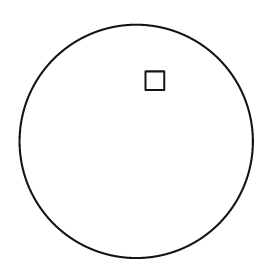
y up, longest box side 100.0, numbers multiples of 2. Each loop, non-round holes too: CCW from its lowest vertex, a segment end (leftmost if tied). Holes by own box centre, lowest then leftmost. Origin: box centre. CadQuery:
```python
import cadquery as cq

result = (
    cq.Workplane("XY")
    .moveTo(0.0, 0.0)
    .circle(50.0)
    .moveTo(4.0, 22.0)
    .lineTo(12.0, 22.0)
    .lineTo(12.0, 30.0)
    .lineTo(4.0, 30.0)
    .close()
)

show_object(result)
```